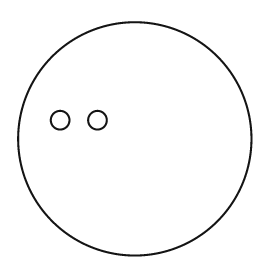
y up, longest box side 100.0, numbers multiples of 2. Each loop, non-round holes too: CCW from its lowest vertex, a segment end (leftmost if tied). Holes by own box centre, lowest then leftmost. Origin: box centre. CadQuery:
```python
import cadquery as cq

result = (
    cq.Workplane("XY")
    .moveTo(0.0, 0.0)
    .circle(50.0)
    .moveTo(-32.0, 8.0)
    .circle(4.0)
    .moveTo(-16.0, 8.0)
    .circle(4.0)
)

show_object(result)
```